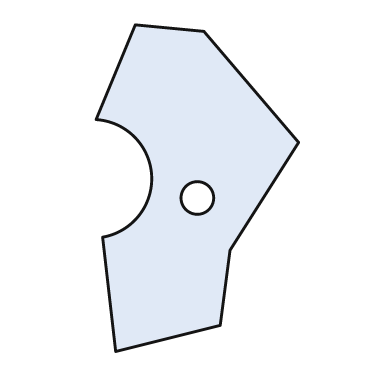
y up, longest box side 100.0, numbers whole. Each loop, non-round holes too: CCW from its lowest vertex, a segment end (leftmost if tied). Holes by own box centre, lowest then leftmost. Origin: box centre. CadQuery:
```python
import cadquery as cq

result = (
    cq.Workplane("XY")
    .moveTo(-25.0, -50.0)
    .lineTo(7.0, -42.0)
    .lineTo(10.0, -19.0)
    .lineTo(31.0, 14.0)
    .lineTo(2.0, 48.0)
    .lineTo(-19.0, 50.0)
    .lineTo(-31.0, 21.0)
    .threePointArc((-14.0, 4.0), (-29.0, -15.0))
    .close()
    .moveTo(0.0, -3.0)
    .circle(5.0)
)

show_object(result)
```